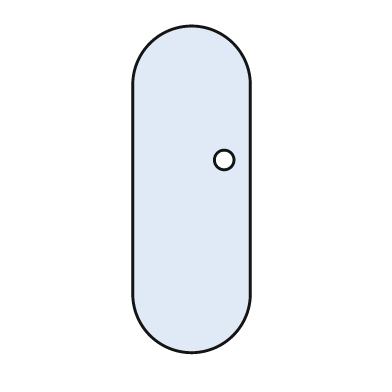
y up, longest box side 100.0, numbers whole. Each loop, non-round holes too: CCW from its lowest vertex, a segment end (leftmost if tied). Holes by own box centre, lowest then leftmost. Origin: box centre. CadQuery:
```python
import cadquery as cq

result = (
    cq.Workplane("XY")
    .moveTo(-18.0, -32.0)
    .threePointArc((0.0, -50.0), (18.0, -32.0))
    .lineTo(18.0, 32.0)
    .threePointArc((0.0, 50.0), (-18.0, 32.0))
    .close()
    .moveTo(10.0, 9.0)
    .circle(3.0)
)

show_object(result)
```